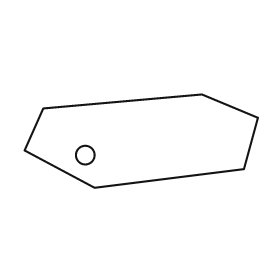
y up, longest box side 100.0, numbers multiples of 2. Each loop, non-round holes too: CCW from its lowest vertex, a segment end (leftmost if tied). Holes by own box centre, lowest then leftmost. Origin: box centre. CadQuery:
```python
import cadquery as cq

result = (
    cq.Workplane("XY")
    .moveTo(-20.0, -20.0)
    .lineTo(44.0, -12.0)
    .lineTo(50.0, 10.0)
    .lineTo(26.0, 20.0)
    .lineTo(-42.0, 14.0)
    .lineTo(-50.0, -4.0)
    .close()
    .moveTo(-24.0, -6.0)
    .circle(4.0)
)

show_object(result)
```